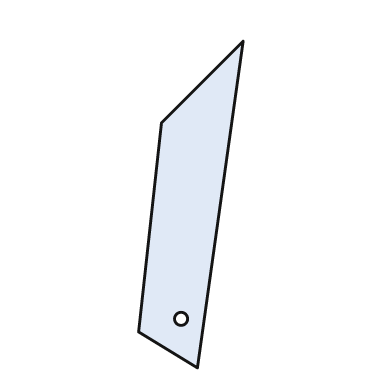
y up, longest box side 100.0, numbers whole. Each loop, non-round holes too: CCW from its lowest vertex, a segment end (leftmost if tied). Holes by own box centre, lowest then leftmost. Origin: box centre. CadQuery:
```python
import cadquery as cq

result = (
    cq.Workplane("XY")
    .moveTo(2.0, -50.0)
    .lineTo(16.0, 50.0)
    .lineTo(-9.0, 25.0)
    .lineTo(-16.0, -39.0)
    .close()
    .moveTo(-3.0, -35.0)
    .circle(2.0)
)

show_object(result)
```